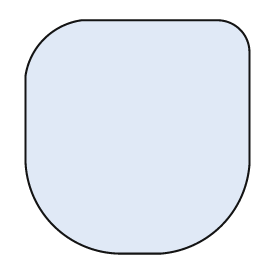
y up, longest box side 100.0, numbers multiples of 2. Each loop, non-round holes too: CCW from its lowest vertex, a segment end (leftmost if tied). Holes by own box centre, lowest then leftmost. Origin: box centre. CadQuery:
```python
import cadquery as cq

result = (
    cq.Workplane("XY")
    .moveTo(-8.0, -50.0)
    .lineTo(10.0, -50.0)
    .threePointArc((36.0, -38.0), (48.0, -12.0))
    .lineTo(48.0, 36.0)
    .threePointArc((44.0, 46.0), (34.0, 50.0))
    .lineTo(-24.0, 50.0)
    .threePointArc((-40.0, 42.0), (-48.0, 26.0))
    .lineTo(-48.0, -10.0)
    .threePointArc((-36.0, -38.0), (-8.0, -50.0))
    .close()
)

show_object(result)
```